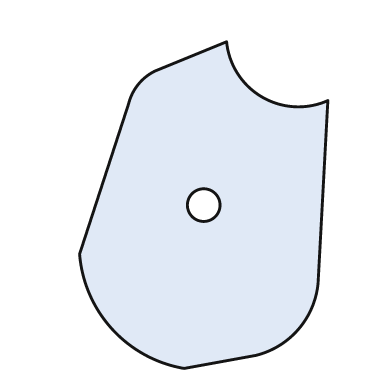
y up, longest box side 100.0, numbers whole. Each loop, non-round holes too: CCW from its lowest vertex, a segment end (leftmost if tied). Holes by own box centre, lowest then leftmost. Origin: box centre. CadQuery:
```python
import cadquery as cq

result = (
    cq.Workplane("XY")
    .moveTo(-6.0, -50.0)
    .lineTo(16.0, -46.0)
    .threePointArc((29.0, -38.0), (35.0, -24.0))
    .lineTo(38.0, 32.0)
    .threePointArc((18.0, 33.0), (7.0, 50.0))
    .lineTo(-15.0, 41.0)
    .threePointArc((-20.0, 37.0), (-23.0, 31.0))
    .lineTo(-38.0, -15.0)
    .threePointArc((-28.0, -38.0), (-6.0, -50.0))
    .close()
    .moveTo(0.0, 0.0)
    .circle(5.0)
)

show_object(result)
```